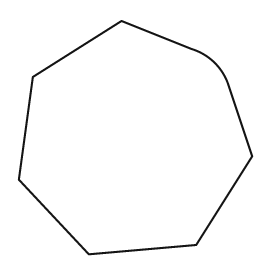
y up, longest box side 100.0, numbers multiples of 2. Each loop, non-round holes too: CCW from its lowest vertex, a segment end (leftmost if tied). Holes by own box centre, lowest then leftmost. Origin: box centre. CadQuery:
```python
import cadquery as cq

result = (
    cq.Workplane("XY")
    .moveTo(-20.0, -50.0)
    .lineTo(26.0, -46.0)
    .lineTo(50.0, -8.0)
    .lineTo(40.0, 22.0)
    .threePointArc((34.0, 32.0), (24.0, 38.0))
    .lineTo(-6.0, 50.0)
    .lineTo(-44.0, 26.0)
    .lineTo(-50.0, -18.0)
    .close()
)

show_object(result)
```